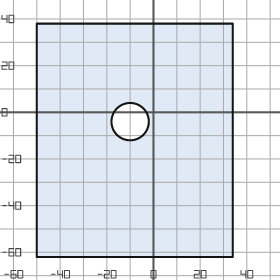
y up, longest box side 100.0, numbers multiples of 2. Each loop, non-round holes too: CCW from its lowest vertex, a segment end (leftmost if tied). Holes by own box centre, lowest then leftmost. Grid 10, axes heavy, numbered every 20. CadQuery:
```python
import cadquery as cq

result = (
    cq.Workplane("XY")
    .moveTo(-50.0, -62.0)
    .lineTo(34.0, -62.0)
    .lineTo(34.0, 38.0)
    .lineTo(-50.0, 38.0)
    .close()
    .moveTo(-10.0, -4.0)
    .circle(8.0)
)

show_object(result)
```